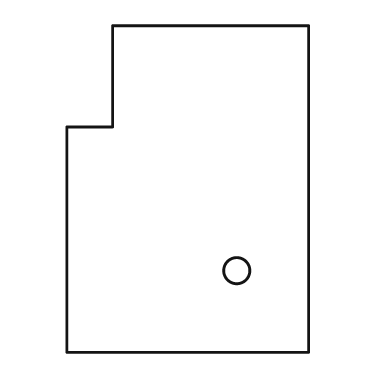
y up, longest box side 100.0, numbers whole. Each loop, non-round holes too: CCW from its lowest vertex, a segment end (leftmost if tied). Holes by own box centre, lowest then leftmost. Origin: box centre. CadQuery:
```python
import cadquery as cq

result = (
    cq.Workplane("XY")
    .moveTo(-37.0, -50.0)
    .lineTo(37.0, -50.0)
    .lineTo(37.0, 50.0)
    .lineTo(-23.0, 50.0)
    .lineTo(-23.0, 19.0)
    .lineTo(-37.0, 19.0)
    .close()
    .moveTo(15.0, -25.0)
    .circle(4.0)
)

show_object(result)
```